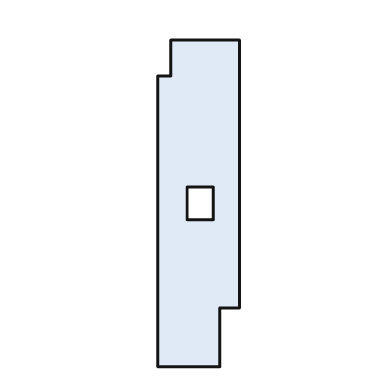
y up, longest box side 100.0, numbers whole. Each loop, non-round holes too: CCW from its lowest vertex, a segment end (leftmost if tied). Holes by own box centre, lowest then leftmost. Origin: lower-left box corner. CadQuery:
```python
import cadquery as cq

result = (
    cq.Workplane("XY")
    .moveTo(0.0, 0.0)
    .lineTo(19.0, 0.0)
    .lineTo(19.0, 18.0)
    .lineTo(25.0, 18.0)
    .lineTo(25.0, 100.0)
    .lineTo(4.0, 100.0)
    .lineTo(4.0, 89.0)
    .lineTo(0.0, 89.0)
    .close()
    .moveTo(9.0, 45.0)
    .lineTo(17.0, 45.0)
    .lineTo(17.0, 55.0)
    .lineTo(9.0, 55.0)
    .close()
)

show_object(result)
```